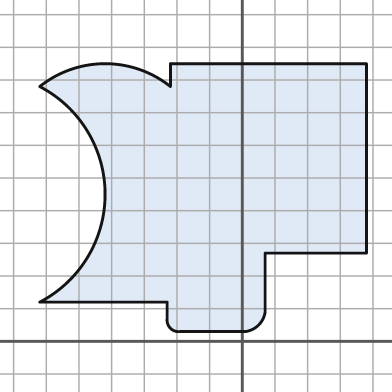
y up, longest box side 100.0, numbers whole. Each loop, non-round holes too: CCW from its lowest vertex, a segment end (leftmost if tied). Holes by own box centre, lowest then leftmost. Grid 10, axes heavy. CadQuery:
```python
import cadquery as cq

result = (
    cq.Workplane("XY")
    .moveTo(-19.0, 3.0)
    .lineTo(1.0, 3.0)
    .threePointArc((5.0, 5.0), (7.0, 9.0))
    .lineTo(7.0, 27.0)
    .lineTo(38.0, 27.0)
    .lineTo(38.0, 85.0)
    .lineTo(-22.0, 85.0)
    .lineTo(-22.0, 78.0)
    .threePointArc((-42.0, 85.0), (-62.0, 78.0))
    .threePointArc((-42.0, 45.0), (-62.0, 12.0))
    .lineTo(-23.0, 12.0)
    .lineTo(-23.0, 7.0)
    .threePointArc((-22.0, 4.0), (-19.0, 3.0))
    .close()
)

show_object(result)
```